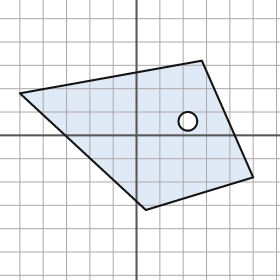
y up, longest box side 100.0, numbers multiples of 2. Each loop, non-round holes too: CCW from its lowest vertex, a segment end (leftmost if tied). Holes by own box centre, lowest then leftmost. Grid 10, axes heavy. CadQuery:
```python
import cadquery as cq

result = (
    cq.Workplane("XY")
    .moveTo(4.0, -32.0)
    .lineTo(50.0, -18.0)
    .lineTo(28.0, 32.0)
    .lineTo(-50.0, 18.0)
    .close()
    .moveTo(22.0, 6.0)
    .circle(4.0)
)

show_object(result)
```